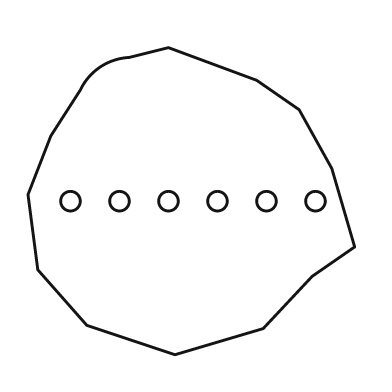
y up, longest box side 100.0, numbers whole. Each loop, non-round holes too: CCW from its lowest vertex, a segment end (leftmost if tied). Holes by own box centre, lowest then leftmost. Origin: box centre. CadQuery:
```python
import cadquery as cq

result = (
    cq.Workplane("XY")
    .moveTo(-5.0, -47.0)
    .lineTo(22.0, -39.0)
    .lineTo(37.0, -23.0)
    .lineTo(50.0, -14.0)
    .lineTo(43.0, 10.0)
    .lineTo(33.0, 28.0)
    .lineTo(20.0, 37.0)
    .lineTo(-7.0, 47.0)
    .lineTo(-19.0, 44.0)
    .threePointArc((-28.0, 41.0), (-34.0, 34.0))
    .lineTo(-43.0, 20.0)
    .lineTo(-50.0, 2.0)
    .lineTo(-47.0, -21.0)
    .lineTo(-32.0, -38.0)
    .close()
    .moveTo(-37.0, 0.0)
    .circle(3.0)
    .moveTo(-22.0, 0.0)
    .circle(3.0)
    .moveTo(-7.0, 0.0)
    .circle(3.0)
    .moveTo(8.0, 0.0)
    .circle(3.0)
    .moveTo(23.0, 0.0)
    .circle(3.0)
    .moveTo(38.0, 0.0)
    .circle(3.0)
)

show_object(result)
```